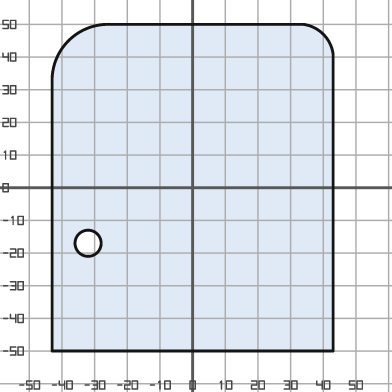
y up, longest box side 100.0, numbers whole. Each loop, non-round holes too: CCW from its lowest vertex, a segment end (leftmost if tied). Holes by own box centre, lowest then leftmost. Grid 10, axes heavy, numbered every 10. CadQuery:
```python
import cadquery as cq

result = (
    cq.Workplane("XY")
    .moveTo(-43.0, -50.0)
    .lineTo(43.0, -50.0)
    .lineTo(43.0, 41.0)
    .threePointArc((40.0, 47.0), (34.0, 50.0))
    .lineTo(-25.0, 50.0)
    .threePointArc((-38.0, 45.0), (-43.0, 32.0))
    .close()
    .moveTo(-32.0, -17.0)
    .circle(4.0)
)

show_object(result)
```